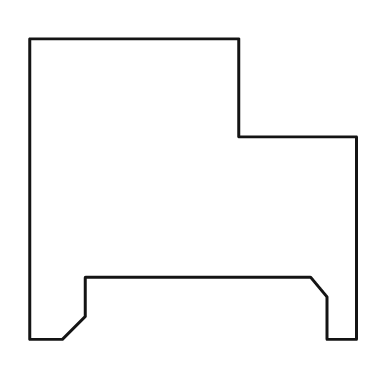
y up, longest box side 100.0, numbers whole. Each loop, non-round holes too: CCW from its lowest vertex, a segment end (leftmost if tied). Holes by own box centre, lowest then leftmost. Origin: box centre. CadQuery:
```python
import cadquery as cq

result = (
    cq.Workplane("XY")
    .moveTo(-50.0, -46.0)
    .lineTo(-40.0, -46.0)
    .lineTo(-33.0, -39.0)
    .lineTo(-33.0, -27.0)
    .lineTo(36.0, -27.0)
    .lineTo(41.0, -33.0)
    .lineTo(41.0, -46.0)
    .lineTo(50.0, -46.0)
    .lineTo(50.0, 16.0)
    .lineTo(14.0, 16.0)
    .lineTo(14.0, 46.0)
    .lineTo(-50.0, 46.0)
    .close()
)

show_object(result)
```